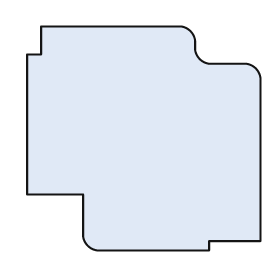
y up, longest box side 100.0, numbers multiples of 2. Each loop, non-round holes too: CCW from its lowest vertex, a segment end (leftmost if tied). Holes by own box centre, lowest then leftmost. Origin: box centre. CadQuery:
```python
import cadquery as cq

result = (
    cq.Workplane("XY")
    .moveTo(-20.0, -48.0)
    .lineTo(28.0, -48.0)
    .lineTo(28.0, -44.0)
    .lineTo(50.0, -44.0)
    .lineTo(50.0, 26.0)
    .threePointArc((48.0, 30.0), (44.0, 32.0))
    .lineTo(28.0, 32.0)
    .threePointArc((24.0, 34.0), (22.0, 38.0))
    .lineTo(22.0, 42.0)
    .threePointArc((20.0, 46.0), (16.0, 48.0))
    .lineTo(-44.0, 48.0)
    .lineTo(-44.0, 36.0)
    .lineTo(-50.0, 36.0)
    .lineTo(-50.0, -24.0)
    .lineTo(-26.0, -24.0)
    .lineTo(-26.0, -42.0)
    .threePointArc((-24.0, -46.0), (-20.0, -48.0))
    .close()
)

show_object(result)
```